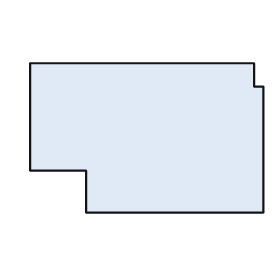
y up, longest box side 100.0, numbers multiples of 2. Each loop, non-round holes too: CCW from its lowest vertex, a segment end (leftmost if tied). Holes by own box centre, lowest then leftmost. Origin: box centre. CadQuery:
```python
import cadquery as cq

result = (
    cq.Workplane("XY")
    .moveTo(-26.0, -32.0)
    .lineTo(50.0, -32.0)
    .lineTo(50.0, 22.0)
    .lineTo(46.0, 22.0)
    .lineTo(46.0, 32.0)
    .lineTo(-50.0, 32.0)
    .lineTo(-50.0, -14.0)
    .lineTo(-26.0, -14.0)
    .close()
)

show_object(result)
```